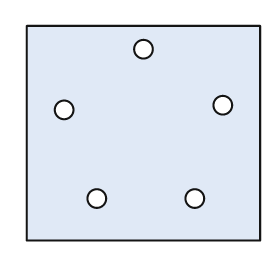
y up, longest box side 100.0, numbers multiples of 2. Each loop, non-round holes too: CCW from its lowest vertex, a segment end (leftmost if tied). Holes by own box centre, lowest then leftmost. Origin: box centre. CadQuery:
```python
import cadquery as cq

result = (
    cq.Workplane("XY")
    .moveTo(-50.0, -46.0)
    .lineTo(50.0, -46.0)
    .lineTo(50.0, 46.0)
    .lineTo(-50.0, 46.0)
    .close()
    .moveTo(-20.0, -28.0)
    .circle(4.0)
    .moveTo(22.0, -28.0)
    .circle(4.0)
    .moveTo(-34.0, 10.0)
    .circle(4.0)
    .moveTo(34.0, 12.0)
    .circle(4.0)
    .moveTo(0.0, 36.0)
    .circle(4.0)
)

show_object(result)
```